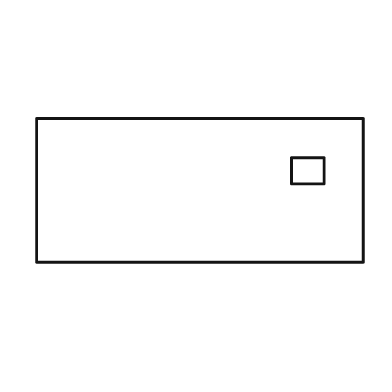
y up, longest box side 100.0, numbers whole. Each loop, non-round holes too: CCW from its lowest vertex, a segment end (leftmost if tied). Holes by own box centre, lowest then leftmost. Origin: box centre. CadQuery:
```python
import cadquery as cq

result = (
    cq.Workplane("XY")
    .moveTo(-50.0, -22.0)
    .lineTo(50.0, -22.0)
    .lineTo(50.0, 22.0)
    .lineTo(-50.0, 22.0)
    .close()
    .moveTo(28.0, 2.0)
    .lineTo(38.0, 2.0)
    .lineTo(38.0, 10.0)
    .lineTo(28.0, 10.0)
    .close()
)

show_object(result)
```